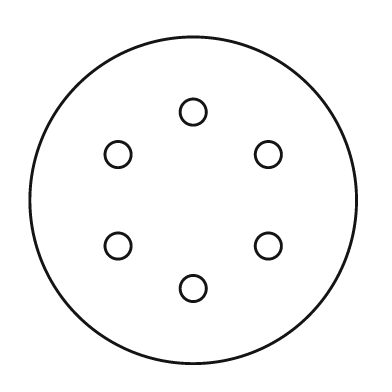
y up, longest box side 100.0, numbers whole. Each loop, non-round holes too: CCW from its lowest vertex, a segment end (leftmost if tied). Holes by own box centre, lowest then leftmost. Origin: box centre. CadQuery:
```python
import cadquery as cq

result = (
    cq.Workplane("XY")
    .moveTo(0.0, 0.0)
    .circle(50.0)
    .moveTo(0.0, -27.0)
    .circle(4.0)
    .moveTo(-23.0, -14.0)
    .circle(4.0)
    .moveTo(23.0, -14.0)
    .circle(4.0)
    .moveTo(-23.0, 14.0)
    .circle(4.0)
    .moveTo(23.0, 14.0)
    .circle(4.0)
    .moveTo(0.0, 27.0)
    .circle(4.0)
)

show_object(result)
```